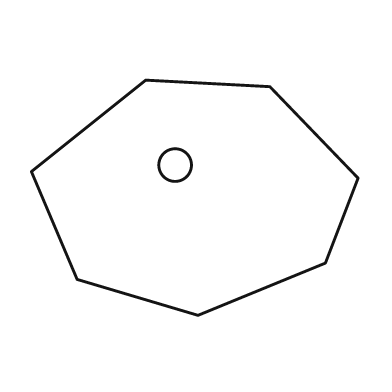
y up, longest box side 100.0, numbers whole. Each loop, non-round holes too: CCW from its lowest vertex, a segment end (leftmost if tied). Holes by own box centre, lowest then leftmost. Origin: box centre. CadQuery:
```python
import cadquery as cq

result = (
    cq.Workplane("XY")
    .moveTo(1.0, -36.0)
    .lineTo(40.0, -20.0)
    .lineTo(50.0, 6.0)
    .lineTo(23.0, 34.0)
    .lineTo(-15.0, 36.0)
    .lineTo(-50.0, 8.0)
    .lineTo(-36.0, -25.0)
    .close()
    .moveTo(-6.0, 10.0)
    .circle(5.0)
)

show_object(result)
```